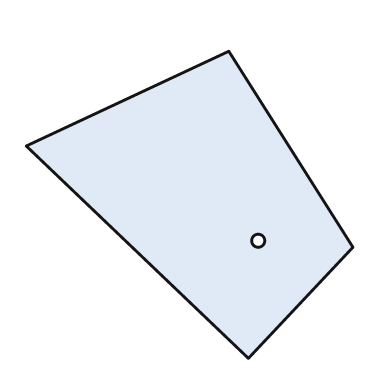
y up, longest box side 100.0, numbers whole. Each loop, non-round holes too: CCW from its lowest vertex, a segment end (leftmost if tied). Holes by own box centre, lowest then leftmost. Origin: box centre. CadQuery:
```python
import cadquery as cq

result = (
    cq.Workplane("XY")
    .moveTo(18.0, -47.0)
    .lineTo(50.0, -13.0)
    .lineTo(12.0, 47.0)
    .lineTo(-50.0, 18.0)
    .close()
    .moveTo(21.0, -11.0)
    .circle(2.0)
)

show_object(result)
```